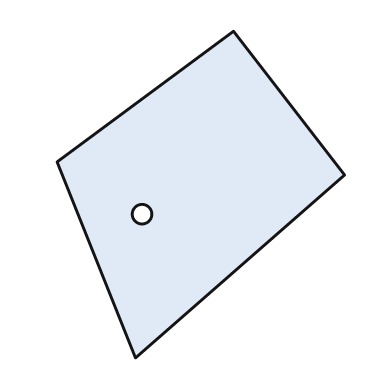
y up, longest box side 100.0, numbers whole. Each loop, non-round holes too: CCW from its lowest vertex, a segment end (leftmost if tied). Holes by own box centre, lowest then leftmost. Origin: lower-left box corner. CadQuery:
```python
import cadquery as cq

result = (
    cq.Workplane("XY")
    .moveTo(24.0, 0.0)
    .lineTo(88.0, 56.0)
    .lineTo(54.0, 100.0)
    .lineTo(0.0, 60.0)
    .close()
    .moveTo(26.0, 44.0)
    .circle(3.0)
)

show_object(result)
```